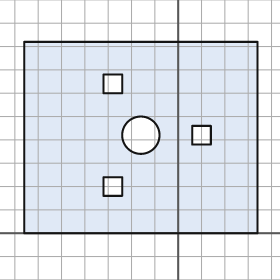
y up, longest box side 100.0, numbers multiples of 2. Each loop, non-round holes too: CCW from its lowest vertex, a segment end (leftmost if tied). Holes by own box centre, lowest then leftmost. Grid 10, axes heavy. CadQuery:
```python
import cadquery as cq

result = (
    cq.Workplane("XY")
    .moveTo(-66.0, 0.0)
    .lineTo(34.0, 0.0)
    .lineTo(34.0, 82.0)
    .lineTo(-66.0, 82.0)
    .close()
    .moveTo(-32.0, 16.0)
    .lineTo(-24.0, 16.0)
    .lineTo(-24.0, 24.0)
    .lineTo(-32.0, 24.0)
    .close()
    .moveTo(-16.0, 42.0)
    .circle(8.0)
    .moveTo(6.0, 38.0)
    .lineTo(14.0, 38.0)
    .lineTo(14.0, 46.0)
    .lineTo(6.0, 46.0)
    .close()
    .moveTo(-32.0, 60.0)
    .lineTo(-24.0, 60.0)
    .lineTo(-24.0, 68.0)
    .lineTo(-32.0, 68.0)
    .close()
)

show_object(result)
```